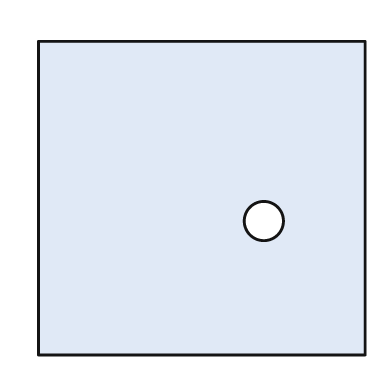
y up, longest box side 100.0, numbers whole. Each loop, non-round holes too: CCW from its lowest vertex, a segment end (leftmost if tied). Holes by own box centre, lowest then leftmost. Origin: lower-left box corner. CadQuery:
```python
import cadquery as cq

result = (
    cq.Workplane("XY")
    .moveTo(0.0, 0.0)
    .lineTo(100.0, 0.0)
    .lineTo(100.0, 96.0)
    .lineTo(0.0, 96.0)
    .close()
    .moveTo(69.0, 41.0)
    .circle(6.0)
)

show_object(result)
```